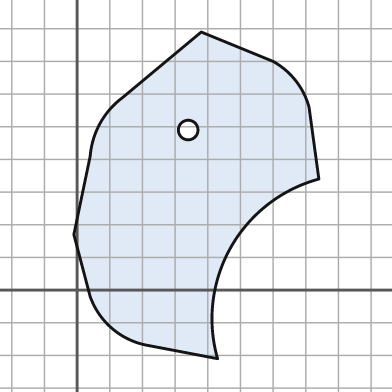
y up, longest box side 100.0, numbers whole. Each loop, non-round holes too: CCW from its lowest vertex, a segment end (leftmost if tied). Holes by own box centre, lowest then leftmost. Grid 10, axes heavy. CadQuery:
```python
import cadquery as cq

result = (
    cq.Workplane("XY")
    .moveTo(43.0, -21.0)
    .threePointArc((47.0, 13.0), (74.0, 34.0))
    .lineTo(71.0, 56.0)
    .threePointArc((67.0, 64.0), (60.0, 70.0))
    .lineTo(38.0, 79.0)
    .lineTo(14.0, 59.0)
    .threePointArc((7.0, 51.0), (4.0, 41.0))
    .lineTo(-1.0, 17.0)
    .lineTo(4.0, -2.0)
    .threePointArc((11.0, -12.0), (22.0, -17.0))
    .close()
    .moveTo(34.0, 49.0)
    .circle(3.0)
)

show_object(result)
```